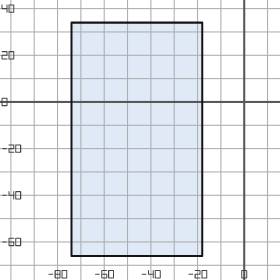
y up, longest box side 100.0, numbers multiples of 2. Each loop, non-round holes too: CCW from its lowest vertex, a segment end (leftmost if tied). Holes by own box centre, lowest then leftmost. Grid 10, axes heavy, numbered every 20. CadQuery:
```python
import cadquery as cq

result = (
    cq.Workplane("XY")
    .moveTo(-74.0, -66.0)
    .lineTo(-18.0, -66.0)
    .lineTo(-18.0, 34.0)
    .lineTo(-74.0, 34.0)
    .close()
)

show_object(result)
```